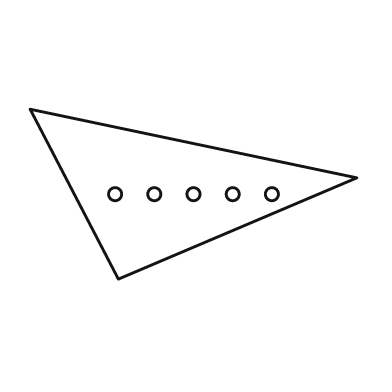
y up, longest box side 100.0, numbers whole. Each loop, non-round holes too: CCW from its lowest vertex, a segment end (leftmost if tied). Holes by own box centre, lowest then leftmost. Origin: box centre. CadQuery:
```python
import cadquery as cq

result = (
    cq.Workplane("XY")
    .moveTo(-23.0, -26.0)
    .lineTo(50.0, 5.0)
    .lineTo(-50.0, 26.0)
    .close()
    .moveTo(-24.0, 0.0)
    .circle(2.0)
    .moveTo(-12.0, 0.0)
    .circle(2.0)
    .moveTo(0.0, 0.0)
    .circle(2.0)
    .moveTo(12.0, 0.0)
    .circle(2.0)
    .moveTo(24.0, 0.0)
    .circle(2.0)
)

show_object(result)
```